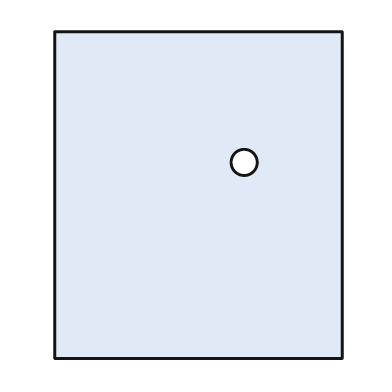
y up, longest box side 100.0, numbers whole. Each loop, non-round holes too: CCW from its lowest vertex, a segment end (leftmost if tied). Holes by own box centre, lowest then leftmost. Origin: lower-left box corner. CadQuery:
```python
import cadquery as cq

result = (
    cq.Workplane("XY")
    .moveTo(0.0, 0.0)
    .lineTo(88.0, 0.0)
    .lineTo(88.0, 100.0)
    .lineTo(0.0, 100.0)
    .close()
    .moveTo(58.0, 60.0)
    .circle(4.0)
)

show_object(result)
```